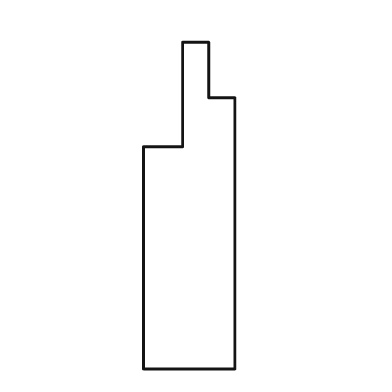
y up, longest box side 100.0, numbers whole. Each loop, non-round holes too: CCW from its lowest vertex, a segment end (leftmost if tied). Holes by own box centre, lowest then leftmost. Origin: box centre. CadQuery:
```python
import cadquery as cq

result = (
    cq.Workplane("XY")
    .moveTo(-14.0, -50.0)
    .lineTo(14.0, -50.0)
    .lineTo(14.0, 33.0)
    .lineTo(6.0, 33.0)
    .lineTo(6.0, 50.0)
    .lineTo(-2.0, 50.0)
    .lineTo(-2.0, 18.0)
    .lineTo(-14.0, 18.0)
    .close()
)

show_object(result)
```